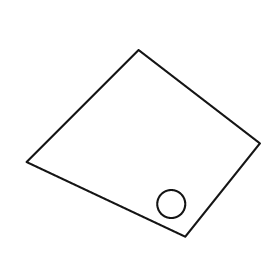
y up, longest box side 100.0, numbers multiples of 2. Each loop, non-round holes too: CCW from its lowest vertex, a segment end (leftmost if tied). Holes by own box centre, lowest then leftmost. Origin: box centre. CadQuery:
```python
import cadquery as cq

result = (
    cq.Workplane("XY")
    .moveTo(18.0, -40.0)
    .lineTo(50.0, 0.0)
    .lineTo(-2.0, 40.0)
    .lineTo(-50.0, -8.0)
    .close()
    .moveTo(12.0, -26.0)
    .circle(6.0)
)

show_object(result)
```